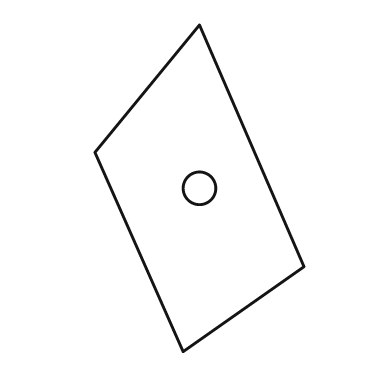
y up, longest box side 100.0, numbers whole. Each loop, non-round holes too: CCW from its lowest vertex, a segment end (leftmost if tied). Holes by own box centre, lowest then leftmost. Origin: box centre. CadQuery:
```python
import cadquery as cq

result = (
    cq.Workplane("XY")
    .moveTo(-5.0, -50.0)
    .lineTo(32.0, -24.0)
    .lineTo(0.0, 50.0)
    .lineTo(-32.0, 11.0)
    .close()
    .moveTo(0.0, 0.0)
    .circle(5.0)
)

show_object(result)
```